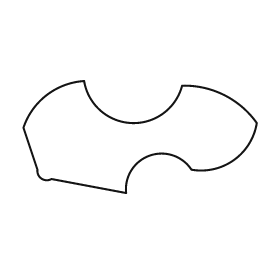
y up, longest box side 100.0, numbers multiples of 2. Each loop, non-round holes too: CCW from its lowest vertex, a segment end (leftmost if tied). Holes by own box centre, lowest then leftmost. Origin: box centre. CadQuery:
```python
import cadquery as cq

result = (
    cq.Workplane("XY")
    .moveTo(-6.0, -24.0)
    .threePointArc((4.0, -8.0), (22.0, -14.0))
    .threePointArc((40.0, -10.0), (50.0, 6.0))
    .threePointArc((36.0, 18.0), (18.0, 22.0))
    .threePointArc((-4.0, 6.0), (-24.0, 24.0))
    .threePointArc((-40.0, 18.0), (-50.0, 4.0))
    .lineTo(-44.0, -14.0)
    .threePointArc((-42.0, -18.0), (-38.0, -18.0))
    .close()
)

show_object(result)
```